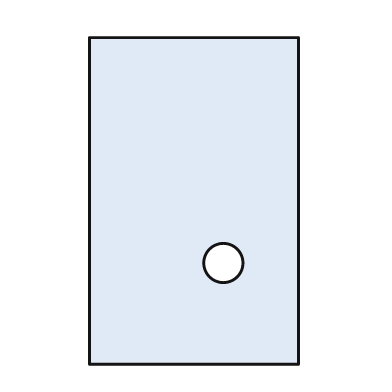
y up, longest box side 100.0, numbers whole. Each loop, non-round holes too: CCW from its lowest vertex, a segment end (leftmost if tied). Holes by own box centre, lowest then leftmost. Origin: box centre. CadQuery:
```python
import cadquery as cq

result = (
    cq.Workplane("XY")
    .moveTo(-32.0, -50.0)
    .lineTo(32.0, -50.0)
    .lineTo(32.0, 50.0)
    .lineTo(-32.0, 50.0)
    .close()
    .moveTo(9.0, -19.0)
    .circle(6.0)
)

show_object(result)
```